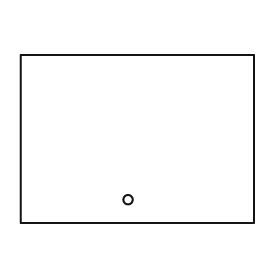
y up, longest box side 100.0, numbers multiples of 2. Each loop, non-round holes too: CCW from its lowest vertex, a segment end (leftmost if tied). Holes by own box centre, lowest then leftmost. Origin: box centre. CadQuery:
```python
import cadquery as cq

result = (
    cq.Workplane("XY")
    .moveTo(-50.0, -36.0)
    .lineTo(50.0, -36.0)
    .lineTo(50.0, 36.0)
    .lineTo(-50.0, 36.0)
    .close()
    .moveTo(-4.0, -26.0)
    .circle(2.0)
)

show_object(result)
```